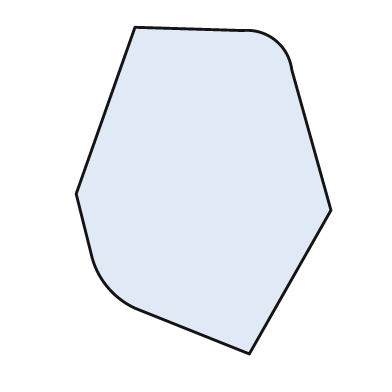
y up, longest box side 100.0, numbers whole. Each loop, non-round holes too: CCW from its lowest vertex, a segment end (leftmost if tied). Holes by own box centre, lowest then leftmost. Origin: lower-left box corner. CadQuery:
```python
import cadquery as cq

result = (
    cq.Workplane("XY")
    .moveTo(53.0, 0.0)
    .lineTo(78.0, 44.0)
    .lineTo(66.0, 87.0)
    .threePointArc((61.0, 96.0), (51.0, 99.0))
    .lineTo(18.0, 100.0)
    .lineTo(0.0, 49.0)
    .lineTo(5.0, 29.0)
    .threePointArc((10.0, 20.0), (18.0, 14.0))
    .close()
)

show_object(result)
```